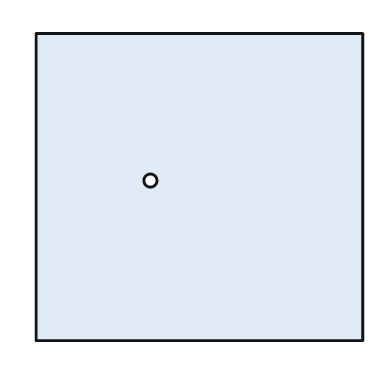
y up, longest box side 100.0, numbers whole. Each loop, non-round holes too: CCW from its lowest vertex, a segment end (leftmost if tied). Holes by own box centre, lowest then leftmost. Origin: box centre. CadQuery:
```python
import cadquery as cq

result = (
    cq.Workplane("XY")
    .moveTo(-50.0, -47.0)
    .lineTo(50.0, -47.0)
    .lineTo(50.0, 47.0)
    .lineTo(-50.0, 47.0)
    .close()
    .moveTo(-15.0, 2.0)
    .circle(2.0)
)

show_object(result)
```